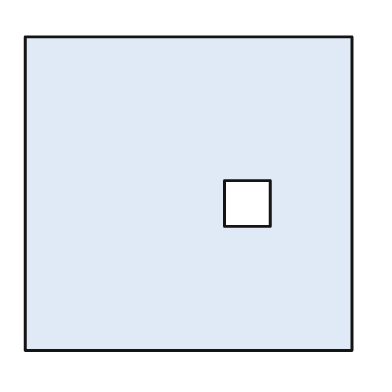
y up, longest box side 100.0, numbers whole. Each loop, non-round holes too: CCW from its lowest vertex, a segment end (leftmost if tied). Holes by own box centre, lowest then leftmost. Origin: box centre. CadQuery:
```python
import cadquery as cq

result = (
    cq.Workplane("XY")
    .moveTo(-50.0, -48.0)
    .lineTo(50.0, -48.0)
    .lineTo(50.0, 48.0)
    .lineTo(-50.0, 48.0)
    .close()
    .moveTo(11.0, -10.0)
    .lineTo(25.0, -10.0)
    .lineTo(25.0, 4.0)
    .lineTo(11.0, 4.0)
    .close()
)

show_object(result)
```